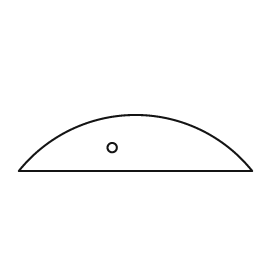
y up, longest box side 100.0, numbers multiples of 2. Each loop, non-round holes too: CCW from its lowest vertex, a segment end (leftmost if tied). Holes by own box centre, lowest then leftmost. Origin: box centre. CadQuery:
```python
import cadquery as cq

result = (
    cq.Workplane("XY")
    .moveTo(-50.0, -12.0)
    .lineTo(50.0, -12.0)
    .threePointArc((0.0, 12.0), (-50.0, -12.0))
    .close()
    .moveTo(-10.0, -2.0)
    .circle(2.0)
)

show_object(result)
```